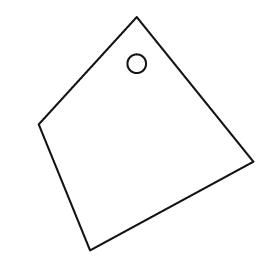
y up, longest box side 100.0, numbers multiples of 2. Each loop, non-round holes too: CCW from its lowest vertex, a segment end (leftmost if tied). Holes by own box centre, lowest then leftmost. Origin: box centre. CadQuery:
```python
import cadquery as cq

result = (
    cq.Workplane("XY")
    .moveTo(-24.0, -50.0)
    .lineTo(46.0, -12.0)
    .lineTo(-4.0, 50.0)
    .lineTo(-46.0, 4.0)
    .close()
    .moveTo(-4.0, 30.0)
    .circle(4.0)
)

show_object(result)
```